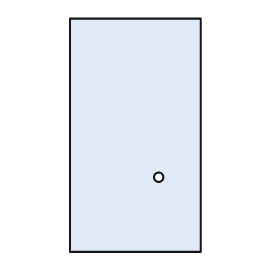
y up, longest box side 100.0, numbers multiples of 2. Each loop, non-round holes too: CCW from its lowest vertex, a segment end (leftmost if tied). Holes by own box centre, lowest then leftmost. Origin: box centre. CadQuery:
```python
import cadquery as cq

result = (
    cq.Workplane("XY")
    .moveTo(-28.0, -50.0)
    .lineTo(28.0, -50.0)
    .lineTo(28.0, 50.0)
    .lineTo(-28.0, 50.0)
    .close()
    .moveTo(10.0, -18.0)
    .circle(2.0)
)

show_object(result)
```